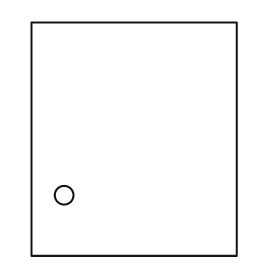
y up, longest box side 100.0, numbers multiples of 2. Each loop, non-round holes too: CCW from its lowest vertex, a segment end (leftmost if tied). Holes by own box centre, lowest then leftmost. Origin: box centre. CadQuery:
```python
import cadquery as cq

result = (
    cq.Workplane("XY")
    .moveTo(-44.0, -50.0)
    .lineTo(44.0, -50.0)
    .lineTo(44.0, 50.0)
    .lineTo(-44.0, 50.0)
    .close()
    .moveTo(-30.0, -24.0)
    .circle(4.0)
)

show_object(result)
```